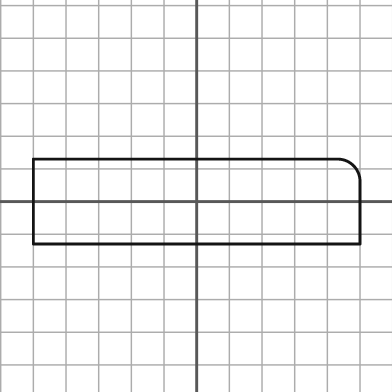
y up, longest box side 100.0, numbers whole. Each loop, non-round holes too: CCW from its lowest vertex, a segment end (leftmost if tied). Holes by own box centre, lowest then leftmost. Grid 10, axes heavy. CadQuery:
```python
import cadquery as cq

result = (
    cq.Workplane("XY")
    .moveTo(-50.0, -13.0)
    .lineTo(50.0, -13.0)
    .lineTo(50.0, 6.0)
    .threePointArc((48.0, 11.0), (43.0, 13.0))
    .lineTo(-50.0, 13.0)
    .close()
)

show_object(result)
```